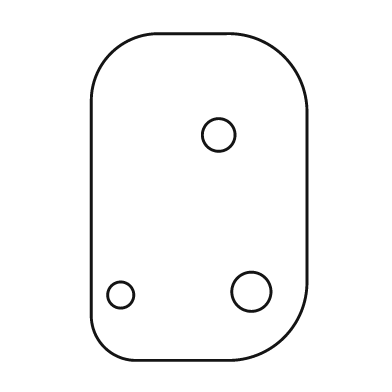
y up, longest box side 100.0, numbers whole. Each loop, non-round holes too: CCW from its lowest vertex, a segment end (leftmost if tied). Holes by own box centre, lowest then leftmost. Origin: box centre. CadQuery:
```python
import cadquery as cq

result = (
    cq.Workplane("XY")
    .moveTo(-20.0, -50.0)
    .lineTo(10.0, -50.0)
    .threePointArc((26.0, -43.0), (33.0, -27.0))
    .lineTo(33.0, 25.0)
    .threePointArc((26.0, 43.0), (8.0, 50.0))
    .lineTo(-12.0, 50.0)
    .threePointArc((-27.0, 44.0), (-33.0, 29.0))
    .lineTo(-33.0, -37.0)
    .threePointArc((-29.0, -46.0), (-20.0, -50.0))
    .close()
    .moveTo(-24.0, -30.0)
    .circle(4.0)
    .moveTo(16.0, -29.0)
    .circle(6.0)
    .moveTo(6.0, 19.0)
    .circle(5.0)
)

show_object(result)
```